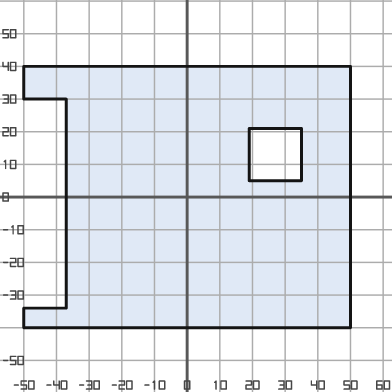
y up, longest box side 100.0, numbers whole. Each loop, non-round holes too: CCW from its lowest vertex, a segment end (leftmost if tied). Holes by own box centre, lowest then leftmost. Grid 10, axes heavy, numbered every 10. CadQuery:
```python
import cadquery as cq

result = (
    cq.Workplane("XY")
    .moveTo(-50.0, -40.0)
    .lineTo(50.0, -40.0)
    .lineTo(50.0, 40.0)
    .lineTo(-50.0, 40.0)
    .lineTo(-50.0, 30.0)
    .lineTo(-37.0, 30.0)
    .lineTo(-37.0, -34.0)
    .lineTo(-50.0, -34.0)
    .close()
    .moveTo(19.0, 5.0)
    .lineTo(35.0, 5.0)
    .lineTo(35.0, 21.0)
    .lineTo(19.0, 21.0)
    .close()
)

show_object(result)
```